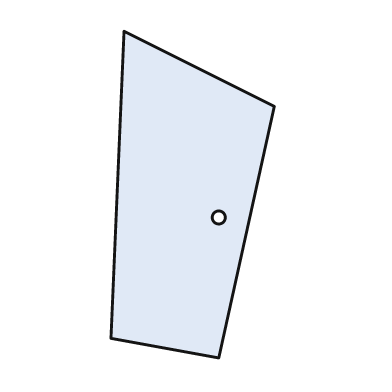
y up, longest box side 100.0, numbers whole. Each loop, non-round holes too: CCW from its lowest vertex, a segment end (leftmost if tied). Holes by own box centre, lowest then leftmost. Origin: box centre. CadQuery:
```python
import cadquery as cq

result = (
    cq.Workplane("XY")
    .moveTo(8.0, -50.0)
    .lineTo(25.0, 27.0)
    .lineTo(-21.0, 50.0)
    .lineTo(-25.0, -44.0)
    .close()
    .moveTo(8.0, -7.0)
    .circle(2.0)
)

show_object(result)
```